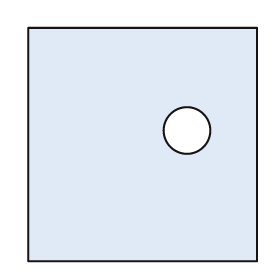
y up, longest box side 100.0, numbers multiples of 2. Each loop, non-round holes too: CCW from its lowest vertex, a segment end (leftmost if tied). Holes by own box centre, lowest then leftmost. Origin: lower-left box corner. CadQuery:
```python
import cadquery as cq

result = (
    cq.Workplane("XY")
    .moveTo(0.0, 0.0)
    .lineTo(98.0, 0.0)
    .lineTo(98.0, 100.0)
    .lineTo(0.0, 100.0)
    .close()
    .moveTo(68.0, 56.0)
    .circle(10.0)
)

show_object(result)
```